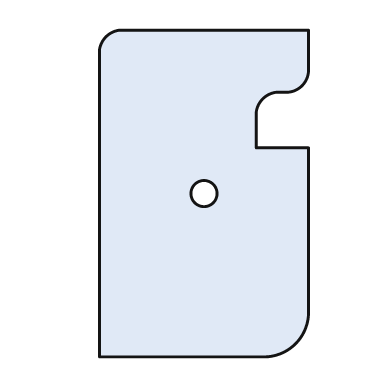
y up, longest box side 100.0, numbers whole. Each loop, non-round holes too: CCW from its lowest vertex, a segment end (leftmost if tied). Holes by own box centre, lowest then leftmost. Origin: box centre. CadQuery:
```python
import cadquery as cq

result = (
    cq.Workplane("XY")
    .moveTo(-32.0, -50.0)
    .lineTo(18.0, -50.0)
    .threePointArc((28.0, -46.0), (32.0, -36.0))
    .lineTo(32.0, 14.0)
    .lineTo(16.0, 14.0)
    .lineTo(16.0, 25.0)
    .threePointArc((18.0, 29.0), (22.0, 31.0))
    .lineTo(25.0, 31.0)
    .threePointArc((30.0, 33.0), (32.0, 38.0))
    .lineTo(32.0, 50.0)
    .lineTo(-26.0, 50.0)
    .threePointArc((-30.0, 48.0), (-32.0, 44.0))
    .close()
    .moveTo(0.0, 0.0)
    .circle(4.0)
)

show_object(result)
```